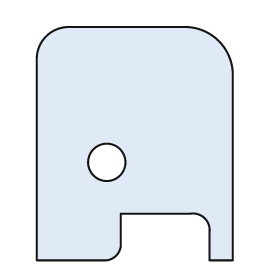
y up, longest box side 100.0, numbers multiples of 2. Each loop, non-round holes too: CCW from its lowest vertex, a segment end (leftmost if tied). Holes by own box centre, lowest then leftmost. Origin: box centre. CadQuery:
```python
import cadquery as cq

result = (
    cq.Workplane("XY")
    .moveTo(-42.0, -50.0)
    .lineTo(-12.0, -50.0)
    .threePointArc((-8.0, -48.0), (-6.0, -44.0))
    .lineTo(-6.0, -30.0)
    .lineTo(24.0, -30.0)
    .threePointArc((30.0, -32.0), (32.0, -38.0))
    .lineTo(32.0, -50.0)
    .lineTo(42.0, -50.0)
    .lineTo(42.0, 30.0)
    .threePointArc((36.0, 44.0), (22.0, 50.0))
    .lineTo(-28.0, 50.0)
    .threePointArc((-38.0, 46.0), (-42.0, 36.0))
    .close()
    .moveTo(-12.0, -8.0)
    .circle(8.0)
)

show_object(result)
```